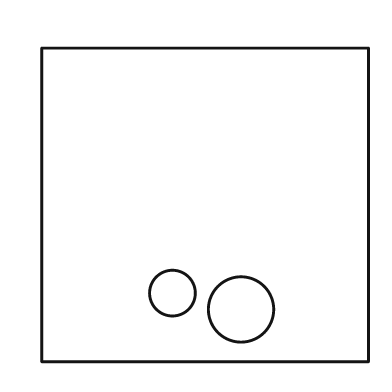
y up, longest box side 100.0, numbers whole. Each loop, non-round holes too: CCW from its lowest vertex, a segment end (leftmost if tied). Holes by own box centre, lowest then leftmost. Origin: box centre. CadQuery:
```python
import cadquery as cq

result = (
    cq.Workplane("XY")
    .moveTo(-50.0, -48.0)
    .lineTo(50.0, -48.0)
    .lineTo(50.0, 48.0)
    .lineTo(-50.0, 48.0)
    .close()
    .moveTo(11.0, -32.0)
    .circle(10.0)
    .moveTo(-10.0, -27.0)
    .circle(7.0)
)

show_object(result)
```